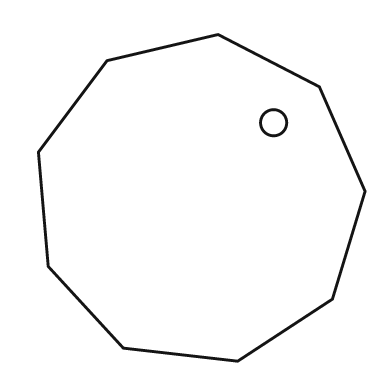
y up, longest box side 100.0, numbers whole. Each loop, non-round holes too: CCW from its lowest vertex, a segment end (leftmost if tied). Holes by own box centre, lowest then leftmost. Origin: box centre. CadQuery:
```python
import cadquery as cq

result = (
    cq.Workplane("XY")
    .moveTo(11.0, -50.0)
    .lineTo(40.0, -31.0)
    .lineTo(50.0, 2.0)
    .lineTo(36.0, 34.0)
    .lineTo(5.0, 50.0)
    .lineTo(-29.0, 42.0)
    .lineTo(-50.0, 14.0)
    .lineTo(-47.0, -21.0)
    .lineTo(-24.0, -46.0)
    .close()
    .moveTo(22.0, 23.0)
    .circle(4.0)
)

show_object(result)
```